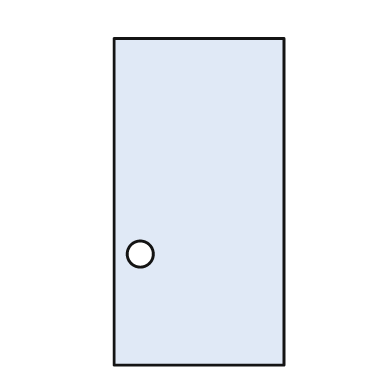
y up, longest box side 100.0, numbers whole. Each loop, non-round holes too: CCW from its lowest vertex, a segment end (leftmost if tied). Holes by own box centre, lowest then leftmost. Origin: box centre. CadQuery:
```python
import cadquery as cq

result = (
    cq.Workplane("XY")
    .moveTo(-26.0, -50.0)
    .lineTo(26.0, -50.0)
    .lineTo(26.0, 50.0)
    .lineTo(-26.0, 50.0)
    .close()
    .moveTo(-18.0, -16.0)
    .circle(4.0)
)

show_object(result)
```